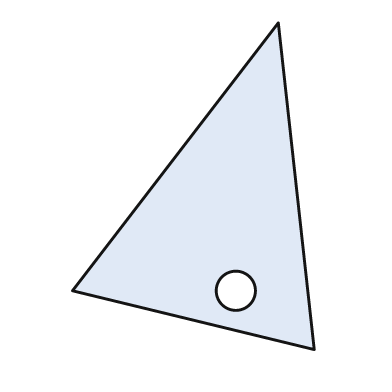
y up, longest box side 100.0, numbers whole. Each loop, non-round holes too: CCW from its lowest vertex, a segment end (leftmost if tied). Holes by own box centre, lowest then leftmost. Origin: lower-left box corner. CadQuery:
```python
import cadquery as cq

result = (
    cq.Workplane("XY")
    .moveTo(74.0, 0.0)
    .lineTo(63.0, 100.0)
    .lineTo(0.0, 18.0)
    .close()
    .moveTo(50.0, 18.0)
    .circle(6.0)
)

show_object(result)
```